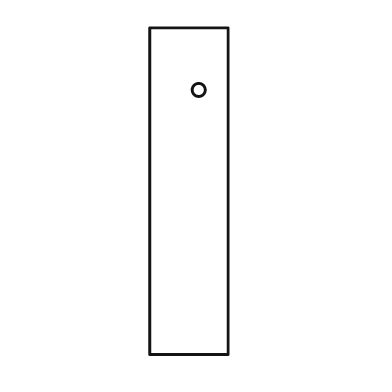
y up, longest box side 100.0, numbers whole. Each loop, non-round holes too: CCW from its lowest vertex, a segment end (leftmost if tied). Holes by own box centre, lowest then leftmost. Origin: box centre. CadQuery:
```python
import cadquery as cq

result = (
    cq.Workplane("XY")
    .moveTo(-12.0, -50.0)
    .lineTo(12.0, -50.0)
    .lineTo(12.0, 50.0)
    .lineTo(-12.0, 50.0)
    .close()
    .moveTo(3.0, 31.0)
    .circle(2.0)
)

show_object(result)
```